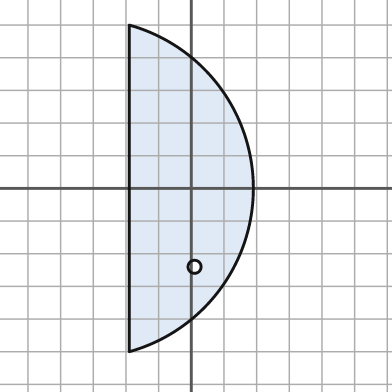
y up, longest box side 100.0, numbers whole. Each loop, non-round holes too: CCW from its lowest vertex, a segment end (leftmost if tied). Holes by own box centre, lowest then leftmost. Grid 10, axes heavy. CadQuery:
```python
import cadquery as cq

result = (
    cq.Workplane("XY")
    .moveTo(-19.0, -50.0)
    .threePointArc((19.0, 0.0), (-19.0, 50.0))
    .close()
    .moveTo(1.0, -24.0)
    .circle(2.0)
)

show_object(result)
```